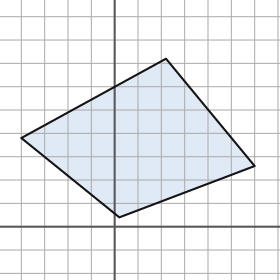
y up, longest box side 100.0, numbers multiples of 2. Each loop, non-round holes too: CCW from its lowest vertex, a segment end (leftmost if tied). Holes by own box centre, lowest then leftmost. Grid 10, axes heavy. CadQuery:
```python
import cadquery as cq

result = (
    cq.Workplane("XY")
    .moveTo(2.0, 4.0)
    .lineTo(60.0, 26.0)
    .lineTo(22.0, 72.0)
    .lineTo(-40.0, 38.0)
    .close()
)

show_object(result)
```